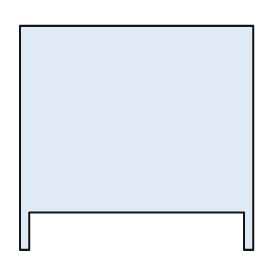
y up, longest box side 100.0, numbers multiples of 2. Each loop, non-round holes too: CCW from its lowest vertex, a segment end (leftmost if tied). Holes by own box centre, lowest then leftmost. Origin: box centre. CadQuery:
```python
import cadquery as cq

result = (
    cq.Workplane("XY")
    .moveTo(-50.0, -48.0)
    .lineTo(-46.0, -48.0)
    .lineTo(-46.0, -32.0)
    .lineTo(46.0, -32.0)
    .lineTo(46.0, -48.0)
    .lineTo(50.0, -48.0)
    .lineTo(50.0, 48.0)
    .lineTo(-50.0, 48.0)
    .close()
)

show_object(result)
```